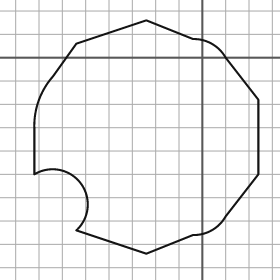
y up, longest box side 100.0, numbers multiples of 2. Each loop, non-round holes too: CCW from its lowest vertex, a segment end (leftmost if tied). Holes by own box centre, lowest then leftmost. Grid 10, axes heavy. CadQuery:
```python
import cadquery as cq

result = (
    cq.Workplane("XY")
    .moveTo(-24.0, -84.0)
    .lineTo(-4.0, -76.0)
    .threePointArc((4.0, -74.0), (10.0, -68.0))
    .lineTo(24.0, -50.0)
    .lineTo(24.0, -18.0)
    .lineTo(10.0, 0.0)
    .threePointArc((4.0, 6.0), (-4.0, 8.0))
    .lineTo(-24.0, 16.0)
    .lineTo(-54.0, 6.0)
    .lineTo(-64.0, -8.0)
    .threePointArc((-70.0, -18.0), (-72.0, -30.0))
    .lineTo(-72.0, -50.0)
    .threePointArc((-52.0, -54.0), (-54.0, -74.0))
    .close()
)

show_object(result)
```